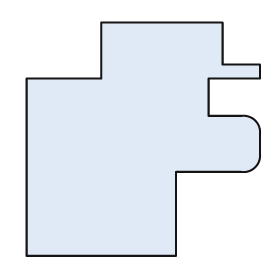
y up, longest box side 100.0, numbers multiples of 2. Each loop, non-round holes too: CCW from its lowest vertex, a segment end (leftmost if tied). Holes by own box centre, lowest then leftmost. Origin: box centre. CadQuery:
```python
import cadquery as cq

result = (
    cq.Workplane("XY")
    .moveTo(-50.0, -50.0)
    .lineTo(14.0, -50.0)
    .lineTo(14.0, -14.0)
    .lineTo(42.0, -14.0)
    .threePointArc((48.0, -12.0), (50.0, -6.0))
    .lineTo(50.0, 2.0)
    .threePointArc((48.0, 8.0), (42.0, 10.0))
    .lineTo(28.0, 10.0)
    .lineTo(28.0, 26.0)
    .lineTo(50.0, 26.0)
    .lineTo(50.0, 32.0)
    .lineTo(34.0, 32.0)
    .lineTo(34.0, 50.0)
    .lineTo(-18.0, 50.0)
    .lineTo(-18.0, 26.0)
    .lineTo(-50.0, 26.0)
    .close()
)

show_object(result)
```